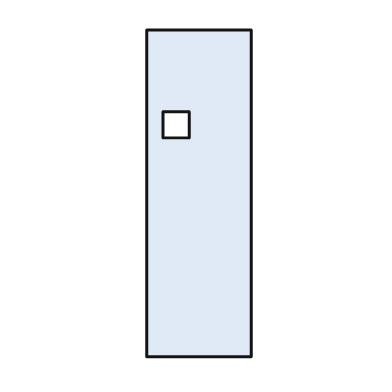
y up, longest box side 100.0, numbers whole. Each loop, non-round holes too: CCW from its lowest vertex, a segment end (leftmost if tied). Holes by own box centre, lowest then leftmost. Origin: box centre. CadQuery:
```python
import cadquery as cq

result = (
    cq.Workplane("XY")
    .moveTo(-16.0, -50.0)
    .lineTo(16.0, -50.0)
    .lineTo(16.0, 50.0)
    .lineTo(-16.0, 50.0)
    .close()
    .moveTo(-11.0, 17.0)
    .lineTo(-3.0, 17.0)
    .lineTo(-3.0, 25.0)
    .lineTo(-11.0, 25.0)
    .close()
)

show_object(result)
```